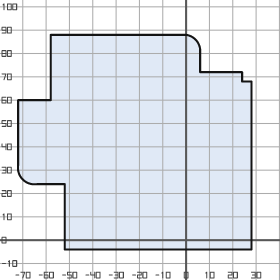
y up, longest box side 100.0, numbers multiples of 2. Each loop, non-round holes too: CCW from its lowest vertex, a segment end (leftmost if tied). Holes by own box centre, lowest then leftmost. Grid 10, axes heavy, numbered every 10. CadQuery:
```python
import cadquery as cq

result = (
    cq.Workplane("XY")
    .moveTo(-52.0, -4.0)
    .lineTo(28.0, -4.0)
    .lineTo(28.0, 68.0)
    .lineTo(24.0, 68.0)
    .lineTo(24.0, 72.0)
    .lineTo(6.0, 72.0)
    .lineTo(6.0, 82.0)
    .threePointArc((4.0, 86.0), (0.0, 88.0))
    .lineTo(-58.0, 88.0)
    .lineTo(-58.0, 60.0)
    .lineTo(-72.0, 60.0)
    .lineTo(-72.0, 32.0)
    .threePointArc((-70.0, 26.0), (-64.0, 24.0))
    .lineTo(-52.0, 24.0)
    .close()
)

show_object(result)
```